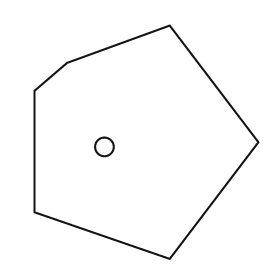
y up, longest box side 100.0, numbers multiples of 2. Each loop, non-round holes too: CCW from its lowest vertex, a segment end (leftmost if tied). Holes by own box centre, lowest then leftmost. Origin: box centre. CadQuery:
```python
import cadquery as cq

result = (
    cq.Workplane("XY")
    .moveTo(10.0, -50.0)
    .lineTo(48.0, 0.0)
    .lineTo(10.0, 50.0)
    .lineTo(-34.0, 34.0)
    .lineTo(-48.0, 22.0)
    .lineTo(-48.0, -30.0)
    .close()
    .moveTo(-18.0, -2.0)
    .circle(4.0)
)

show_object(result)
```